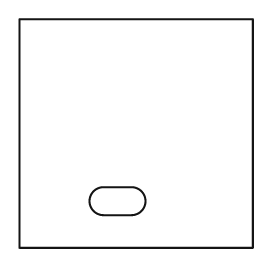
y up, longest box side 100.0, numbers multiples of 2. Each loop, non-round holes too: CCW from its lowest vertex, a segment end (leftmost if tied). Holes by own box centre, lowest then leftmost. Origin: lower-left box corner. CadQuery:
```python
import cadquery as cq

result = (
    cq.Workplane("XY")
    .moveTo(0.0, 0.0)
    .lineTo(100.0, 0.0)
    .lineTo(100.0, 98.0)
    .lineTo(0.0, 98.0)
    .close()
    .moveTo(36.0, 14.0)
    .lineTo(48.0, 14.0)
    .threePointArc((54.0, 20.0), (48.0, 26.0))
    .lineTo(36.0, 26.0)
    .threePointArc((30.0, 20.0), (36.0, 14.0))
    .close()
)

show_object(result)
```